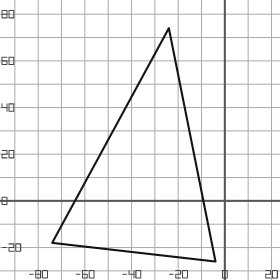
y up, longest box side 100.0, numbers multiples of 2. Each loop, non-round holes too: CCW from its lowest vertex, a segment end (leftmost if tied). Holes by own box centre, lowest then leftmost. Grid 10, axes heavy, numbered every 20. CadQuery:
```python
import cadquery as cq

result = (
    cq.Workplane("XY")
    .moveTo(-4.0, -26.0)
    .lineTo(-24.0, 74.0)
    .lineTo(-74.0, -18.0)
    .close()
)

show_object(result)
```